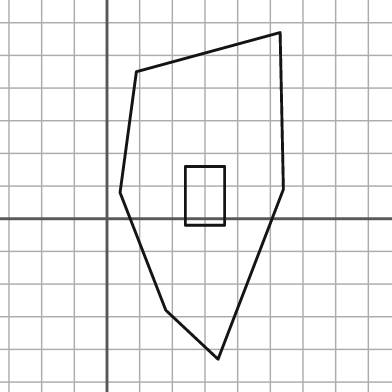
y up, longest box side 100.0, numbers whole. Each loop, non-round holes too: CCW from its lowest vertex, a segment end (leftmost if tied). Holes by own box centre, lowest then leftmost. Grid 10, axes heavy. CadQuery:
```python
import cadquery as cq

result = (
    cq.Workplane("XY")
    .moveTo(34.0, -43.0)
    .lineTo(54.0, 9.0)
    .lineTo(53.0, 57.0)
    .lineTo(9.0, 45.0)
    .lineTo(4.0, 8.0)
    .lineTo(18.0, -28.0)
    .close()
    .moveTo(24.0, -2.0)
    .lineTo(36.0, -2.0)
    .lineTo(36.0, 16.0)
    .lineTo(24.0, 16.0)
    .close()
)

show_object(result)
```